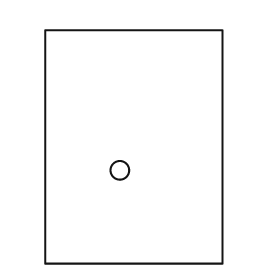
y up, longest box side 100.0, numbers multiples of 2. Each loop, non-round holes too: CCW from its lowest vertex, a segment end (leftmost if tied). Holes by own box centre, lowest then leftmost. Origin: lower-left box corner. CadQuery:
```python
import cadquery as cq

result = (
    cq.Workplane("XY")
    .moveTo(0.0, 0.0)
    .lineTo(76.0, 0.0)
    .lineTo(76.0, 100.0)
    .lineTo(0.0, 100.0)
    .close()
    .moveTo(32.0, 40.0)
    .circle(4.0)
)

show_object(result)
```